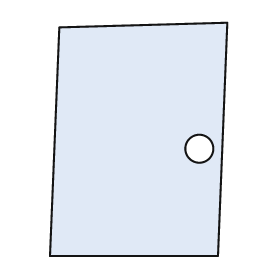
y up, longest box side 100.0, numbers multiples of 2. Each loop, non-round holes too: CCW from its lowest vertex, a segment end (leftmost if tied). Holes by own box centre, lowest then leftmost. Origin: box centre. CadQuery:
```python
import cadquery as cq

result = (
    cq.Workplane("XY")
    .moveTo(-38.0, -50.0)
    .lineTo(34.0, -50.0)
    .lineTo(38.0, 50.0)
    .lineTo(-34.0, 48.0)
    .close()
    .moveTo(26.0, -4.0)
    .circle(6.0)
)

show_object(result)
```